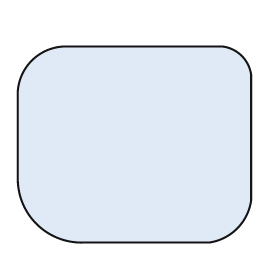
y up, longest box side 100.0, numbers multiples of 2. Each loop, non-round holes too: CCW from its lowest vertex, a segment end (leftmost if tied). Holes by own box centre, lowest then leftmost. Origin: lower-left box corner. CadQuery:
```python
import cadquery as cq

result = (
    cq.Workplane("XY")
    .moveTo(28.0, 0.0)
    .lineTo(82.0, 0.0)
    .threePointArc((94.0, 6.0), (100.0, 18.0))
    .lineTo(100.0, 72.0)
    .threePointArc((96.0, 80.0), (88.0, 84.0))
    .lineTo(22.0, 84.0)
    .threePointArc((6.0, 78.0), (0.0, 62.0))
    .lineTo(0.0, 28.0)
    .threePointArc((8.0, 8.0), (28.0, 0.0))
    .close()
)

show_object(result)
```